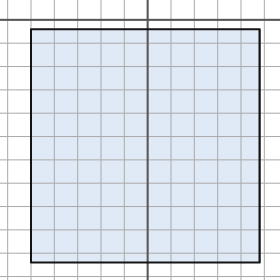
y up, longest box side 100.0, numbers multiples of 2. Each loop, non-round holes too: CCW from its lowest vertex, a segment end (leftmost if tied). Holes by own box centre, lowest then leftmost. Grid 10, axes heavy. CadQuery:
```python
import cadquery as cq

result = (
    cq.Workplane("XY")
    .moveTo(-50.0, -104.0)
    .lineTo(48.0, -104.0)
    .lineTo(48.0, -4.0)
    .lineTo(-50.0, -4.0)
    .close()
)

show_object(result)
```